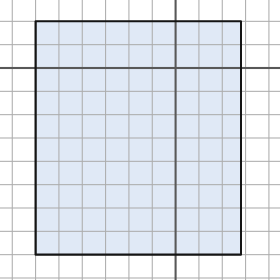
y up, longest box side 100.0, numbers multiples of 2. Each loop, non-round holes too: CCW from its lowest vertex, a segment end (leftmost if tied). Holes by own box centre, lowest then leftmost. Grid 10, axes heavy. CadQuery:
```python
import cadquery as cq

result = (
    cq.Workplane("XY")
    .moveTo(-60.0, -80.0)
    .lineTo(28.0, -80.0)
    .lineTo(28.0, 20.0)
    .lineTo(-60.0, 20.0)
    .close()
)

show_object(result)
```